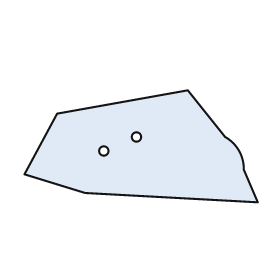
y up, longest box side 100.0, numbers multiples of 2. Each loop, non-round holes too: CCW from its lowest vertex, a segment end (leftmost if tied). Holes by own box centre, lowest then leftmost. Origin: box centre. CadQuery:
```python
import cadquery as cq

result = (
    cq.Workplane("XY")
    .moveTo(50.0, -24.0)
    .lineTo(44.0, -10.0)
    .threePointArc((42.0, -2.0), (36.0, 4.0))
    .lineTo(20.0, 24.0)
    .lineTo(-36.0, 14.0)
    .lineTo(-50.0, -12.0)
    .lineTo(-24.0, -20.0)
    .close()
    .moveTo(-16.0, -2.0)
    .circle(2.0)
    .moveTo(-2.0, 4.0)
    .circle(2.0)
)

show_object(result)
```